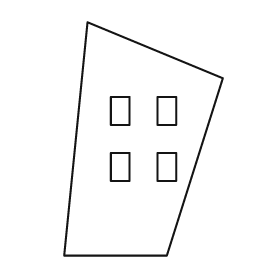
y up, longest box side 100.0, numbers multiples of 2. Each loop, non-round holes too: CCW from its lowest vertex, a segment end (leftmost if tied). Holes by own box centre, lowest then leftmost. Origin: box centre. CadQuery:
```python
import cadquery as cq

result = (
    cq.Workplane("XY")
    .moveTo(-34.0, -50.0)
    .lineTo(10.0, -50.0)
    .lineTo(34.0, 26.0)
    .lineTo(-24.0, 50.0)
    .close()
    .moveTo(-14.0, -18.0)
    .lineTo(-6.0, -18.0)
    .lineTo(-6.0, -6.0)
    .lineTo(-14.0, -6.0)
    .close()
    .moveTo(6.0, -18.0)
    .lineTo(14.0, -18.0)
    .lineTo(14.0, -6.0)
    .lineTo(6.0, -6.0)
    .close()
    .moveTo(-14.0, 6.0)
    .lineTo(-6.0, 6.0)
    .lineTo(-6.0, 18.0)
    .lineTo(-14.0, 18.0)
    .close()
    .moveTo(6.0, 6.0)
    .lineTo(14.0, 6.0)
    .lineTo(14.0, 18.0)
    .lineTo(6.0, 18.0)
    .close()
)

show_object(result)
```